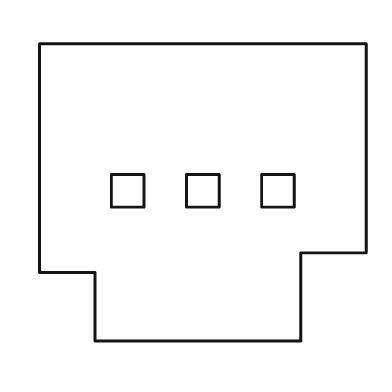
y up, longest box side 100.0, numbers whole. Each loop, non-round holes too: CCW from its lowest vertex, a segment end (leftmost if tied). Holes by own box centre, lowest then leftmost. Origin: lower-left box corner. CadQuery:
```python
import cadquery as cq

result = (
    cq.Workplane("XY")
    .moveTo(17.0, 0.0)
    .lineTo(80.0, 0.0)
    .lineTo(80.0, 27.0)
    .lineTo(100.0, 27.0)
    .lineTo(100.0, 91.0)
    .lineTo(0.0, 91.0)
    .lineTo(0.0, 21.0)
    .lineTo(17.0, 21.0)
    .close()
    .moveTo(22.0, 41.0)
    .lineTo(32.0, 41.0)
    .lineTo(32.0, 51.0)
    .lineTo(22.0, 51.0)
    .close()
    .moveTo(45.0, 41.0)
    .lineTo(55.0, 41.0)
    .lineTo(55.0, 51.0)
    .lineTo(45.0, 51.0)
    .close()
    .moveTo(68.0, 41.0)
    .lineTo(78.0, 41.0)
    .lineTo(78.0, 51.0)
    .lineTo(68.0, 51.0)
    .close()
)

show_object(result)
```